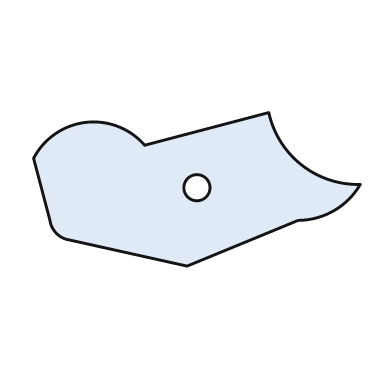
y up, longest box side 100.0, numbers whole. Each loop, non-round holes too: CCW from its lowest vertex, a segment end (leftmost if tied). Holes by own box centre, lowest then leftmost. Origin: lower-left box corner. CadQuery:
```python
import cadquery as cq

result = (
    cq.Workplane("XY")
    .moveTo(47.0, 0.0)
    .lineTo(81.0, 14.0)
    .threePointArc((92.0, 17.0), (100.0, 25.0))
    .threePointArc((82.0, 31.0), (72.0, 47.0))
    .lineTo(34.0, 37.0)
    .threePointArc((16.0, 44.0), (0.0, 33.0))
    .lineTo(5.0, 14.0)
    .threePointArc((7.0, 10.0), (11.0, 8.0))
    .close()
    .moveTo(50.0, 24.0)
    .circle(4.0)
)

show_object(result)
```